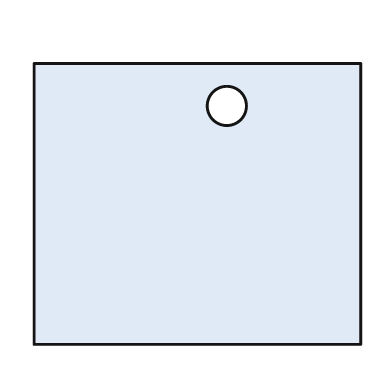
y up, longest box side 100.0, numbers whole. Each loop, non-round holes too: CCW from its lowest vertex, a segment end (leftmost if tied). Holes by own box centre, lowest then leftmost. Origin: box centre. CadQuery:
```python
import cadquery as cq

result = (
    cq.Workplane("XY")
    .moveTo(-50.0, -43.0)
    .lineTo(50.0, -43.0)
    .lineTo(50.0, 43.0)
    .lineTo(-50.0, 43.0)
    .close()
    .moveTo(9.0, 30.0)
    .circle(6.0)
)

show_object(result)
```